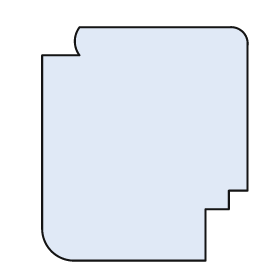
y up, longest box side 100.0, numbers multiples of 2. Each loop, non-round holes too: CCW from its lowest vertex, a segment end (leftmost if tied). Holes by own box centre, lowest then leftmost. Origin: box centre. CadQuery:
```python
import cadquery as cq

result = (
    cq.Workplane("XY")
    .moveTo(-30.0, -50.0)
    .lineTo(26.0, -50.0)
    .lineTo(26.0, -28.0)
    .lineTo(36.0, -28.0)
    .lineTo(36.0, -20.0)
    .lineTo(44.0, -20.0)
    .lineTo(44.0, 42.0)
    .threePointArc((42.0, 48.0), (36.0, 50.0))
    .lineTo(-28.0, 50.0)
    .threePointArc((-30.0, 44.0), (-28.0, 38.0))
    .lineTo(-44.0, 38.0)
    .lineTo(-44.0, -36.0)
    .threePointArc((-40.0, -46.0), (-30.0, -50.0))
    .close()
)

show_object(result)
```